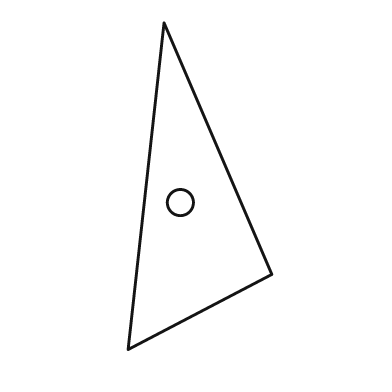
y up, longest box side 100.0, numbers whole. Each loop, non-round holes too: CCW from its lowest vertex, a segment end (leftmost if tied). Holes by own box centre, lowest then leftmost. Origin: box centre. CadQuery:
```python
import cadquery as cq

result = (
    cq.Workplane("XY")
    .moveTo(-22.0, -50.0)
    .lineTo(22.0, -27.0)
    .lineTo(-11.0, 50.0)
    .close()
    .moveTo(-6.0, -5.0)
    .circle(4.0)
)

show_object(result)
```